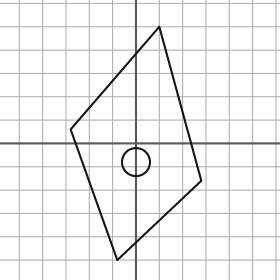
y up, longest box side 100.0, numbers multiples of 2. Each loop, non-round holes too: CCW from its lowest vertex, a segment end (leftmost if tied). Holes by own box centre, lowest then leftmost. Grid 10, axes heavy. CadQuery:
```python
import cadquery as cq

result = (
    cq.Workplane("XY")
    .moveTo(-8.0, -50.0)
    .lineTo(28.0, -16.0)
    .lineTo(10.0, 50.0)
    .lineTo(-28.0, 6.0)
    .close()
    .moveTo(0.0, -8.0)
    .circle(6.0)
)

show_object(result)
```